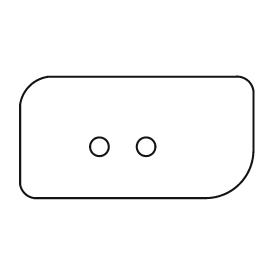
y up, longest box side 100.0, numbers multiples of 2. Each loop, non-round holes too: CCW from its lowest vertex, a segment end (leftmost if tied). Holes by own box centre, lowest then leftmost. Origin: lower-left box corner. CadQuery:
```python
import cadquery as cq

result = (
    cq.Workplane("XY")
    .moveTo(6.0, 0.0)
    .lineTo(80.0, 0.0)
    .threePointArc((94.0, 6.0), (100.0, 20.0))
    .lineTo(100.0, 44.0)
    .threePointArc((98.0, 50.0), (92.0, 52.0))
    .lineTo(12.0, 52.0)
    .threePointArc((4.0, 48.0), (0.0, 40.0))
    .lineTo(0.0, 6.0)
    .threePointArc((2.0, 2.0), (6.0, 0.0))
    .close()
    .moveTo(34.0, 22.0)
    .circle(4.0)
    .moveTo(54.0, 22.0)
    .circle(4.0)
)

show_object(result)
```